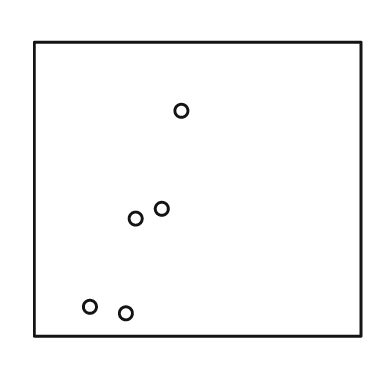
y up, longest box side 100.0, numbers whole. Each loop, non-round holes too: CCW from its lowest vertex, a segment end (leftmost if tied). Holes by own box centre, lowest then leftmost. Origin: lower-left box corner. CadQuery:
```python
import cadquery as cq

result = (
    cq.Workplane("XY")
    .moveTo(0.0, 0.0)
    .lineTo(100.0, 0.0)
    .lineTo(100.0, 90.0)
    .lineTo(0.0, 90.0)
    .close()
    .moveTo(28.0, 7.0)
    .circle(2.0)
    .moveTo(17.0, 9.0)
    .circle(2.0)
    .moveTo(31.0, 36.0)
    .circle(2.0)
    .moveTo(39.0, 39.0)
    .circle(2.0)
    .moveTo(45.0, 69.0)
    .circle(2.0)
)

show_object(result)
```